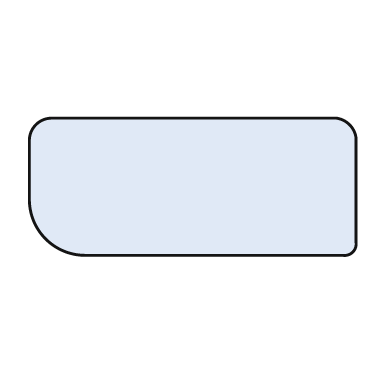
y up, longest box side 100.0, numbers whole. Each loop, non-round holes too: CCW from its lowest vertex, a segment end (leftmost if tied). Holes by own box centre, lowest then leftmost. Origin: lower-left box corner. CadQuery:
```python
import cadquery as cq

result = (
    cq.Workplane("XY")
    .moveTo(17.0, 0.0)
    .lineTo(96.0, 0.0)
    .threePointArc((99.0, 1.0), (100.0, 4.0))
    .lineTo(100.0, 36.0)
    .threePointArc((98.0, 40.0), (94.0, 42.0))
    .lineTo(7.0, 42.0)
    .threePointArc((2.0, 40.0), (0.0, 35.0))
    .lineTo(0.0, 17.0)
    .threePointArc((5.0, 5.0), (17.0, 0.0))
    .close()
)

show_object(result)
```